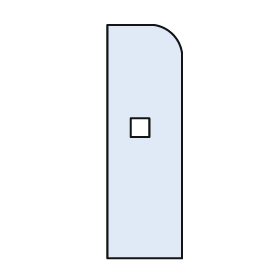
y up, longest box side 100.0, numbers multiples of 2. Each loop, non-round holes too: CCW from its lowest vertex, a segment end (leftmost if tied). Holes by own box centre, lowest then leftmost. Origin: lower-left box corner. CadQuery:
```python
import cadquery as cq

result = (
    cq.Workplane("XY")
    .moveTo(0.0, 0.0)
    .lineTo(32.0, 0.0)
    .lineTo(32.0, 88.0)
    .threePointArc((28.0, 96.0), (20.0, 100.0))
    .lineTo(0.0, 100.0)
    .close()
    .moveTo(10.0, 52.0)
    .lineTo(18.0, 52.0)
    .lineTo(18.0, 60.0)
    .lineTo(10.0, 60.0)
    .close()
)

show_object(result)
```